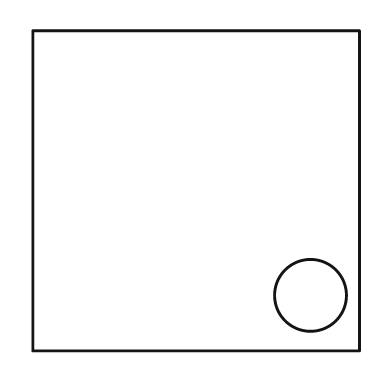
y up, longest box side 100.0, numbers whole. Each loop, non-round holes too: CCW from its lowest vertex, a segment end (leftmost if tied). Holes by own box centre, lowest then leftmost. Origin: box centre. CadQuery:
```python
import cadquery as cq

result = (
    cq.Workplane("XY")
    .moveTo(-50.0, -49.0)
    .lineTo(50.0, -49.0)
    .lineTo(50.0, 49.0)
    .lineTo(-50.0, 49.0)
    .close()
    .moveTo(35.0, -32.0)
    .circle(11.0)
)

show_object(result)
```